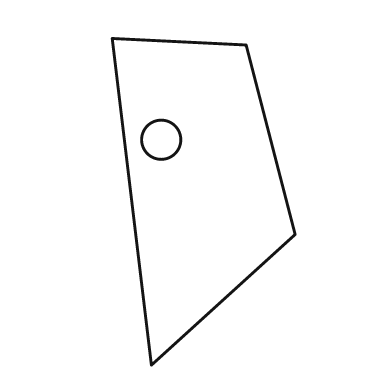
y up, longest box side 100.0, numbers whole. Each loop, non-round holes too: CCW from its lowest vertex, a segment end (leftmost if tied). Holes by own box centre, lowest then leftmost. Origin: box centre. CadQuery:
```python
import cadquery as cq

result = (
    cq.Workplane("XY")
    .moveTo(-16.0, -50.0)
    .lineTo(28.0, -10.0)
    .lineTo(13.0, 48.0)
    .lineTo(-28.0, 50.0)
    .close()
    .moveTo(-13.0, 19.0)
    .circle(6.0)
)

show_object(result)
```